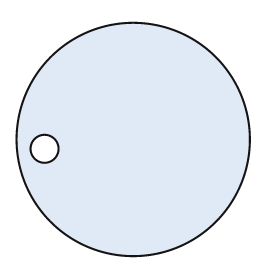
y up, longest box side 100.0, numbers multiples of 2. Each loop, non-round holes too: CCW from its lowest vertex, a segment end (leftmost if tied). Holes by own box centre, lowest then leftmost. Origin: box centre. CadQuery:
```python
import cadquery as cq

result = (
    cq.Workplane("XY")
    .moveTo(0.0, 0.0)
    .circle(50.0)
    .moveTo(-38.0, -4.0)
    .circle(6.0)
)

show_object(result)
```